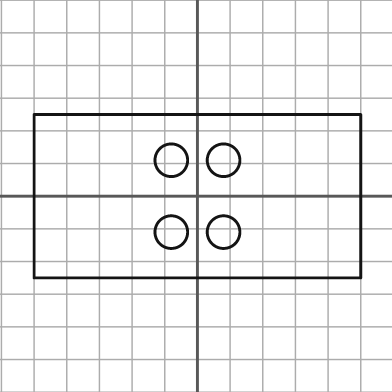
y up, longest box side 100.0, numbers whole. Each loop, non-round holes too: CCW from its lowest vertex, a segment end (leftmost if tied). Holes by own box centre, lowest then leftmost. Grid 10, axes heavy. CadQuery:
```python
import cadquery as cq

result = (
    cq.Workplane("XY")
    .moveTo(-50.0, -25.0)
    .lineTo(50.0, -25.0)
    .lineTo(50.0, 25.0)
    .lineTo(-50.0, 25.0)
    .close()
    .moveTo(-8.0, -11.0)
    .circle(5.0)
    .moveTo(8.0, -11.0)
    .circle(5.0)
    .moveTo(-8.0, 11.0)
    .circle(5.0)
    .moveTo(8.0, 11.0)
    .circle(5.0)
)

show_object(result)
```